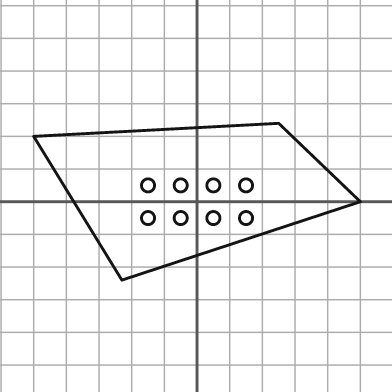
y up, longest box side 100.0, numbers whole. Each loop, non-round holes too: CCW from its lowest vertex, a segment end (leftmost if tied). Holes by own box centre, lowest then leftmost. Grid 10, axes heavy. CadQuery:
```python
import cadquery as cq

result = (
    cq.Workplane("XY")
    .moveTo(-23.0, -24.0)
    .lineTo(50.0, 0.0)
    .lineTo(25.0, 24.0)
    .lineTo(-50.0, 20.0)
    .close()
    .moveTo(-15.0, -5.0)
    .circle(2.0)
    .moveTo(-5.0, -5.0)
    .circle(2.0)
    .moveTo(5.0, -5.0)
    .circle(2.0)
    .moveTo(15.0, -5.0)
    .circle(2.0)
    .moveTo(-15.0, 5.0)
    .circle(2.0)
    .moveTo(-5.0, 5.0)
    .circle(2.0)
    .moveTo(5.0, 5.0)
    .circle(2.0)
    .moveTo(15.0, 5.0)
    .circle(2.0)
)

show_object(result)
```